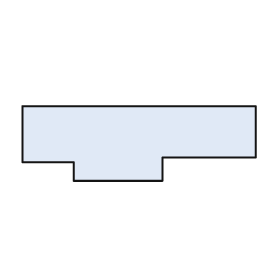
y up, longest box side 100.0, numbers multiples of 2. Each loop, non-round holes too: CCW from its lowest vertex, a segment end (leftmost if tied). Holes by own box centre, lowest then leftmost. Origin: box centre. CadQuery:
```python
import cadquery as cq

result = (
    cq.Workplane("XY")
    .moveTo(-28.0, -16.0)
    .lineTo(10.0, -16.0)
    .lineTo(10.0, -6.0)
    .lineTo(50.0, -6.0)
    .lineTo(50.0, 16.0)
    .lineTo(-50.0, 16.0)
    .lineTo(-50.0, -8.0)
    .lineTo(-28.0, -8.0)
    .close()
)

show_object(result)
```